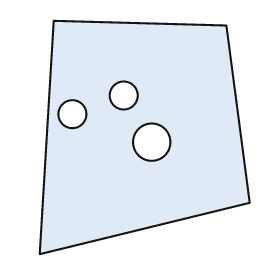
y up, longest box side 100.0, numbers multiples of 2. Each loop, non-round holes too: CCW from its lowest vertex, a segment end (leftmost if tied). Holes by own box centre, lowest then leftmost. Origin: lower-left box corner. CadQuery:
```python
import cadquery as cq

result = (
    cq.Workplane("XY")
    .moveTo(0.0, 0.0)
    .lineTo(90.0, 22.0)
    .lineTo(80.0, 98.0)
    .lineTo(6.0, 100.0)
    .close()
    .moveTo(48.0, 48.0)
    .circle(8.0)
    .moveTo(14.0, 60.0)
    .circle(6.0)
    .moveTo(36.0, 68.0)
    .circle(6.0)
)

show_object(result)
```